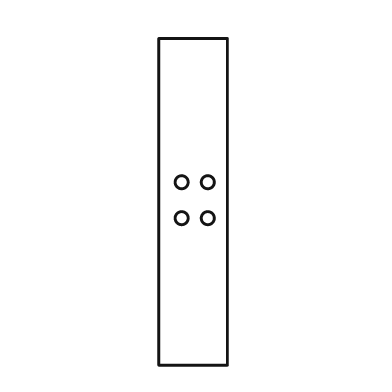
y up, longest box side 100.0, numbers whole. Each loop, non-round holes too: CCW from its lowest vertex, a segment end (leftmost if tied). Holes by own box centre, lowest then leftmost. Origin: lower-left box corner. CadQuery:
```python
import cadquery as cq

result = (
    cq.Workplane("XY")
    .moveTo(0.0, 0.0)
    .lineTo(21.0, 0.0)
    .lineTo(21.0, 100.0)
    .lineTo(0.0, 100.0)
    .close()
    .moveTo(7.0, 45.0)
    .circle(2.0)
    .moveTo(15.0, 45.0)
    .circle(2.0)
    .moveTo(7.0, 56.0)
    .circle(2.0)
    .moveTo(15.0, 56.0)
    .circle(2.0)
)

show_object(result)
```